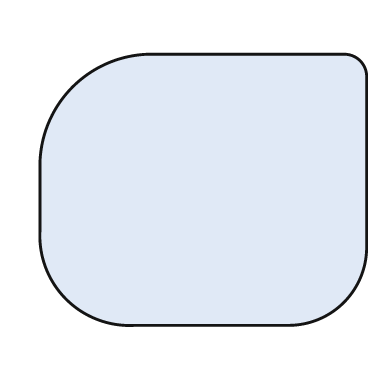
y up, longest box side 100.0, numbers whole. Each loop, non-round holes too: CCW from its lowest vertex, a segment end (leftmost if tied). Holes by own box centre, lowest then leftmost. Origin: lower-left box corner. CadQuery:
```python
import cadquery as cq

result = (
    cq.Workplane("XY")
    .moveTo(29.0, 0.0)
    .lineTo(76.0, 0.0)
    .threePointArc((93.0, 7.0), (100.0, 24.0))
    .lineTo(100.0, 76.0)
    .threePointArc((98.0, 81.0), (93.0, 83.0))
    .lineTo(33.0, 83.0)
    .threePointArc((10.0, 73.0), (0.0, 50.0))
    .lineTo(0.0, 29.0)
    .threePointArc((8.0, 8.0), (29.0, 0.0))
    .close()
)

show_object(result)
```